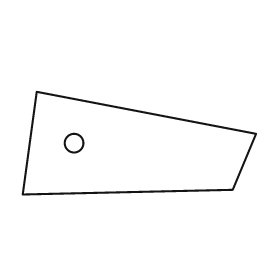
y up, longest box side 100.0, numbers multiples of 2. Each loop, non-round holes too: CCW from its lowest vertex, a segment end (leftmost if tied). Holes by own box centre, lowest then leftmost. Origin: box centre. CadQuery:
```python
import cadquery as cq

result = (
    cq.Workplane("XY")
    .moveTo(-50.0, -22.0)
    .lineTo(40.0, -20.0)
    .lineTo(50.0, 4.0)
    .lineTo(-44.0, 22.0)
    .close()
    .moveTo(-28.0, 0.0)
    .circle(4.0)
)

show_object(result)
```